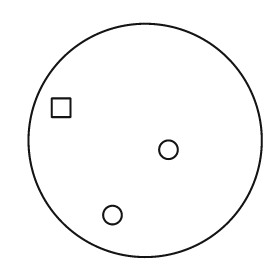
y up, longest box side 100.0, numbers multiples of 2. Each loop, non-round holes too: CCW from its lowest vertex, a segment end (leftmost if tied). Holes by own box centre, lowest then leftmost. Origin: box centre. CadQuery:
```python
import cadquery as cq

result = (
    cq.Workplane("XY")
    .moveTo(0.0, 0.0)
    .circle(50.0)
    .moveTo(-14.0, -32.0)
    .circle(4.0)
    .moveTo(10.0, -4.0)
    .circle(4.0)
    .moveTo(-40.0, 10.0)
    .lineTo(-32.0, 10.0)
    .lineTo(-32.0, 18.0)
    .lineTo(-40.0, 18.0)
    .close()
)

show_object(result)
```